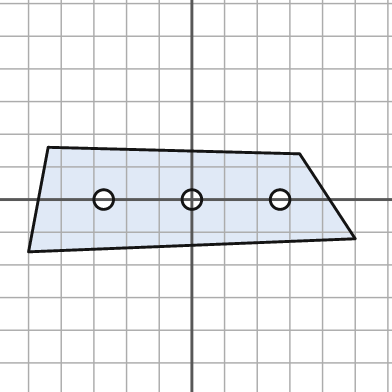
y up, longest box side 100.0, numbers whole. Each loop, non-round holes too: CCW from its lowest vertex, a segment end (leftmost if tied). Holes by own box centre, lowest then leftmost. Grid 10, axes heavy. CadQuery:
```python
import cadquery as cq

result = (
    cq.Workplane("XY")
    .moveTo(-50.0, -16.0)
    .lineTo(50.0, -12.0)
    .lineTo(33.0, 14.0)
    .lineTo(-44.0, 16.0)
    .close()
    .moveTo(-27.0, 0.0)
    .circle(3.0)
    .moveTo(0.0, 0.0)
    .circle(3.0)
    .moveTo(27.0, 0.0)
    .circle(3.0)
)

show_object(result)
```